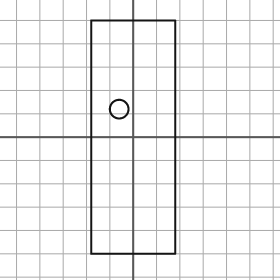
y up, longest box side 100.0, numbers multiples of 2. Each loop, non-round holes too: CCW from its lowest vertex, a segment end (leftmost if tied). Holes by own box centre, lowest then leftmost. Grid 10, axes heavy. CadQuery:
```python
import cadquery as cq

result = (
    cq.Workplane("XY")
    .moveTo(-18.0, -50.0)
    .lineTo(18.0, -50.0)
    .lineTo(18.0, 50.0)
    .lineTo(-18.0, 50.0)
    .close()
    .moveTo(-6.0, 12.0)
    .circle(4.0)
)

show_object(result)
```